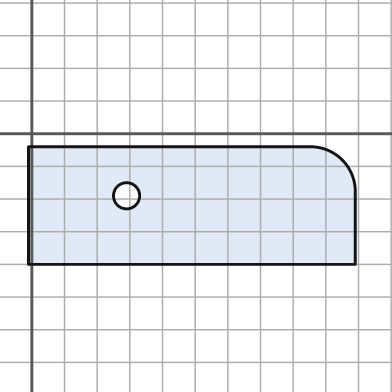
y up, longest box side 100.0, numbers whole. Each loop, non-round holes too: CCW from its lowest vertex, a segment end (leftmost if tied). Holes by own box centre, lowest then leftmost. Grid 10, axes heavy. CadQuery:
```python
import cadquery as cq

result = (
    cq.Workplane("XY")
    .moveTo(-1.0, -40.0)
    .lineTo(99.0, -40.0)
    .lineTo(99.0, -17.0)
    .threePointArc((95.0, -8.0), (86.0, -4.0))
    .lineTo(-1.0, -4.0)
    .close()
    .moveTo(29.0, -19.0)
    .circle(4.0)
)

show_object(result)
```